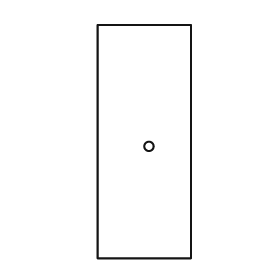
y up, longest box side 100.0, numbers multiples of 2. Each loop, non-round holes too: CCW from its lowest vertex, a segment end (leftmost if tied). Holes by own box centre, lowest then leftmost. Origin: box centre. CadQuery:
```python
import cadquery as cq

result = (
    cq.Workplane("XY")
    .moveTo(-20.0, -50.0)
    .lineTo(20.0, -50.0)
    .lineTo(20.0, 50.0)
    .lineTo(-20.0, 50.0)
    .close()
    .moveTo(2.0, -2.0)
    .circle(2.0)
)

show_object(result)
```